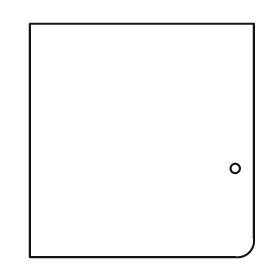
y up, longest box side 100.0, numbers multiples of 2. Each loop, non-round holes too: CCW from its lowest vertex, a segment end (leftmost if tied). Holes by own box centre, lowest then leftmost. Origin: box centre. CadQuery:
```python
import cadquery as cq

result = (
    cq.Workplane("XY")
    .moveTo(-48.0, -50.0)
    .lineTo(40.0, -50.0)
    .threePointArc((46.0, -48.0), (48.0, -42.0))
    .lineTo(48.0, 50.0)
    .lineTo(-48.0, 50.0)
    .close()
    .moveTo(40.0, -12.0)
    .circle(2.0)
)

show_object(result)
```